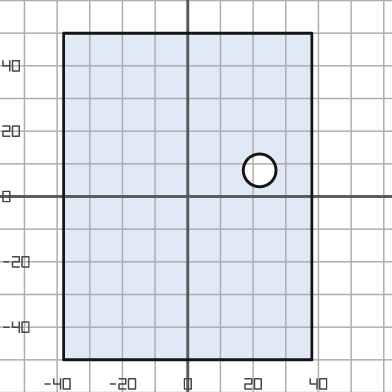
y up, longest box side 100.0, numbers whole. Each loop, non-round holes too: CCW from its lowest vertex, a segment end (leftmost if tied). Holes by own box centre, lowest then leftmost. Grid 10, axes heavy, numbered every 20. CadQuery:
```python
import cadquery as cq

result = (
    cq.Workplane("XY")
    .moveTo(-38.0, -50.0)
    .lineTo(38.0, -50.0)
    .lineTo(38.0, 50.0)
    .lineTo(-38.0, 50.0)
    .close()
    .moveTo(22.0, 8.0)
    .circle(5.0)
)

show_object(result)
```